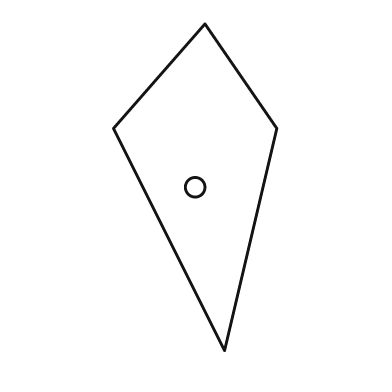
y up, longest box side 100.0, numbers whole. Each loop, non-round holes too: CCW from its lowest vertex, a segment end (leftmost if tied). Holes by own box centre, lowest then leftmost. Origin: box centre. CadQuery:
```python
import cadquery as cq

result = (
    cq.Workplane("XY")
    .moveTo(9.0, -50.0)
    .lineTo(25.0, 18.0)
    .lineTo(3.0, 50.0)
    .lineTo(-25.0, 18.0)
    .close()
    .moveTo(0.0, 0.0)
    .circle(3.0)
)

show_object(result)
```